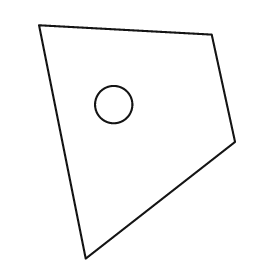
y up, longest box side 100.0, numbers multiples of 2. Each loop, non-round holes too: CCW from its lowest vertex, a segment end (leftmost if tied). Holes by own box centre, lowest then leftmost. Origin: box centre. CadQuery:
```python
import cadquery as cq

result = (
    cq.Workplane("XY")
    .moveTo(-22.0, -50.0)
    .lineTo(42.0, 0.0)
    .lineTo(32.0, 46.0)
    .lineTo(-42.0, 50.0)
    .close()
    .moveTo(-10.0, 16.0)
    .circle(8.0)
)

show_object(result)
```